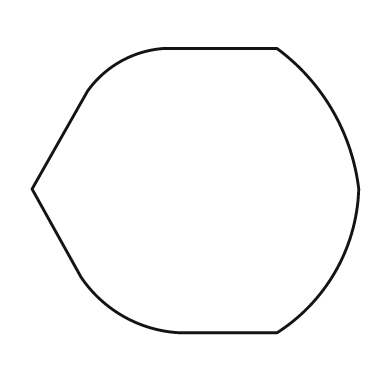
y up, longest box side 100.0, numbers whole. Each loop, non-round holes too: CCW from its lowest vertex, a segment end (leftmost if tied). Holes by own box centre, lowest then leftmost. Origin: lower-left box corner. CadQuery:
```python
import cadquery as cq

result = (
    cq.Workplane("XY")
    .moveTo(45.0, 0.0)
    .lineTo(75.0, 0.0)
    .threePointArc((93.0, 19.0), (100.0, 44.0))
    .threePointArc((92.0, 68.0), (75.0, 87.0))
    .lineTo(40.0, 87.0)
    .threePointArc((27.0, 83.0), (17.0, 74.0))
    .lineTo(0.0, 44.0)
    .lineTo(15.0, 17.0)
    .threePointArc((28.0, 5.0), (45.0, 0.0))
    .close()
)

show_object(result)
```